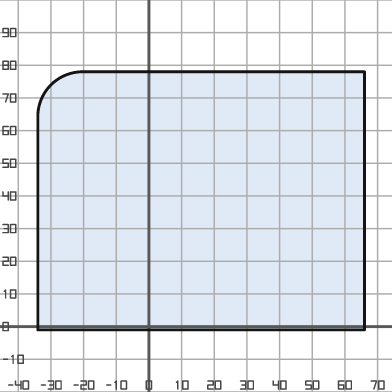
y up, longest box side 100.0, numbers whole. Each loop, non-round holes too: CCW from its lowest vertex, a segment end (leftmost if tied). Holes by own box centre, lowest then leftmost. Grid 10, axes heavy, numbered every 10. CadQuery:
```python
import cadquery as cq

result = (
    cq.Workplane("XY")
    .moveTo(-34.0, -1.0)
    .lineTo(66.0, -1.0)
    .lineTo(66.0, 78.0)
    .lineTo(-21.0, 78.0)
    .threePointArc((-30.0, 74.0), (-34.0, 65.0))
    .close()
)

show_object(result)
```